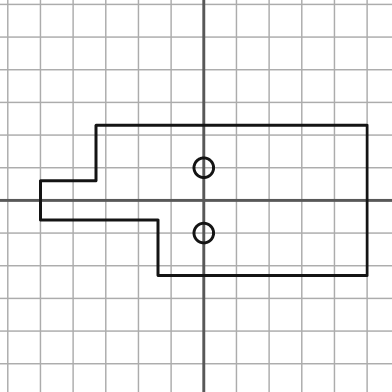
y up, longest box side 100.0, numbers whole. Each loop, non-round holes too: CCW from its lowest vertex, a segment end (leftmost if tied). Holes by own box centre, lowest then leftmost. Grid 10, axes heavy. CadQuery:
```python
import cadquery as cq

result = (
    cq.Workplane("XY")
    .moveTo(-14.0, -23.0)
    .lineTo(50.0, -23.0)
    .lineTo(50.0, 23.0)
    .lineTo(-33.0, 23.0)
    .lineTo(-33.0, 6.0)
    .lineTo(-50.0, 6.0)
    .lineTo(-50.0, -6.0)
    .lineTo(-14.0, -6.0)
    .close()
    .moveTo(0.0, -10.0)
    .circle(3.0)
    .moveTo(0.0, 10.0)
    .circle(3.0)
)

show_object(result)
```